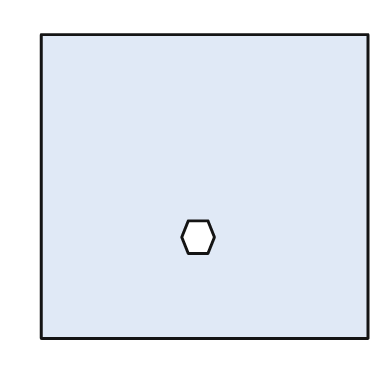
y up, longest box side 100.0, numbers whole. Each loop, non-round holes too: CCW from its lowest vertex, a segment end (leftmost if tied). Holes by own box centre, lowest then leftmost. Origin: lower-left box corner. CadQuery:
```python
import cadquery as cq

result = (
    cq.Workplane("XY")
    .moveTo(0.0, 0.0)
    .lineTo(100.0, 0.0)
    .lineTo(100.0, 93.0)
    .lineTo(0.0, 93.0)
    .close()
    .moveTo(45.0, 26.0)
    .lineTo(51.0, 26.0)
    .lineTo(53.0, 31.0)
    .lineTo(51.0, 36.0)
    .lineTo(45.0, 36.0)
    .lineTo(43.0, 31.0)
    .close()
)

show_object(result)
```